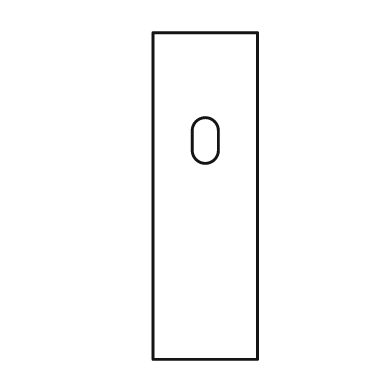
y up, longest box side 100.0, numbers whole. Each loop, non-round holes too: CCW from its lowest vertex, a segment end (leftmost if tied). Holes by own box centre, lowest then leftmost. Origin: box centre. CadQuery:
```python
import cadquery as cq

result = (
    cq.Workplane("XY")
    .moveTo(-16.0, -50.0)
    .lineTo(16.0, -50.0)
    .lineTo(16.0, 50.0)
    .lineTo(-16.0, 50.0)
    .close()
    .moveTo(-4.0, 14.0)
    .threePointArc((0.0, 10.0), (4.0, 14.0))
    .lineTo(4.0, 20.0)
    .threePointArc((0.0, 24.0), (-4.0, 20.0))
    .close()
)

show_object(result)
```